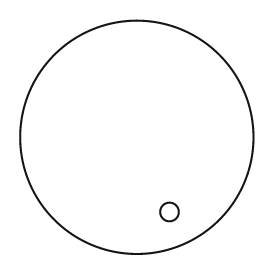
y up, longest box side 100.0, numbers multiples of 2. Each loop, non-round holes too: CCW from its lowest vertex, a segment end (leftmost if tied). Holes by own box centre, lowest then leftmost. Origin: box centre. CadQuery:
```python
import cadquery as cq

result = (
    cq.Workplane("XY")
    .moveTo(0.0, 0.0)
    .circle(50.0)
    .moveTo(14.0, -32.0)
    .circle(4.0)
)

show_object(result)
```